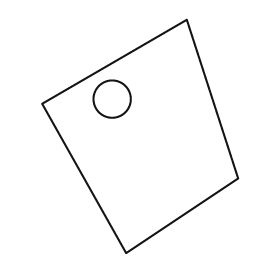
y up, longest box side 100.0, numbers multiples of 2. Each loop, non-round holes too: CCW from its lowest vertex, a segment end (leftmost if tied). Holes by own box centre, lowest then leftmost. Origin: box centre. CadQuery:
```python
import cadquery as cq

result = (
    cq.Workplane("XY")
    .moveTo(-6.0, -50.0)
    .lineTo(42.0, -18.0)
    .lineTo(20.0, 50.0)
    .lineTo(-42.0, 14.0)
    .close()
    .moveTo(-12.0, 16.0)
    .circle(8.0)
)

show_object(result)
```